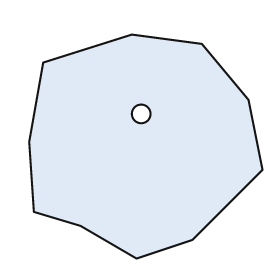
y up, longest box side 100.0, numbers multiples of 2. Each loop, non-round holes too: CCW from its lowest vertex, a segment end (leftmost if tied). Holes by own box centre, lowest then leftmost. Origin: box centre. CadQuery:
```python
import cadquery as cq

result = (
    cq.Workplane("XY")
    .moveTo(-4.0, -48.0)
    .lineTo(20.0, -40.0)
    .lineTo(50.0, -10.0)
    .lineTo(44.0, 20.0)
    .lineTo(24.0, 44.0)
    .lineTo(-6.0, 48.0)
    .lineTo(-44.0, 36.0)
    .lineTo(-50.0, 2.0)
    .lineTo(-48.0, -28.0)
    .lineTo(-28.0, -34.0)
    .close()
    .moveTo(-2.0, 14.0)
    .circle(4.0)
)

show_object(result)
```